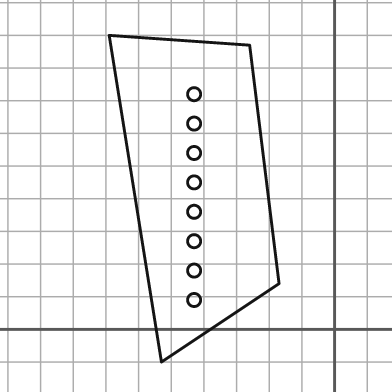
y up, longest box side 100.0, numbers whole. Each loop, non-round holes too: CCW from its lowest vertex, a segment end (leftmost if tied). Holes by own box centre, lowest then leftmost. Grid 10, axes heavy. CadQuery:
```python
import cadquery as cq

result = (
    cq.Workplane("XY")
    .moveTo(-53.0, -10.0)
    .lineTo(-17.0, 14.0)
    .lineTo(-26.0, 87.0)
    .lineTo(-69.0, 90.0)
    .close()
    .moveTo(-43.0, 9.0)
    .circle(2.0)
    .moveTo(-43.0, 18.0)
    .circle(2.0)
    .moveTo(-43.0, 27.0)
    .circle(2.0)
    .moveTo(-43.0, 36.0)
    .circle(2.0)
    .moveTo(-43.0, 45.0)
    .circle(2.0)
    .moveTo(-43.0, 54.0)
    .circle(2.0)
    .moveTo(-43.0, 63.0)
    .circle(2.0)
    .moveTo(-43.0, 72.0)
    .circle(2.0)
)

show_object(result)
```